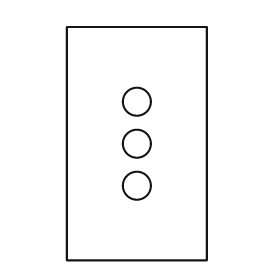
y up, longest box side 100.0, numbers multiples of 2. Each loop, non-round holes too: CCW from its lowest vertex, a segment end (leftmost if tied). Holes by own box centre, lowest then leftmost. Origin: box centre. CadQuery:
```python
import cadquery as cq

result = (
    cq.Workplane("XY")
    .moveTo(-30.0, -50.0)
    .lineTo(30.0, -50.0)
    .lineTo(30.0, 50.0)
    .lineTo(-30.0, 50.0)
    .close()
    .moveTo(0.0, -18.0)
    .circle(6.0)
    .moveTo(0.0, 0.0)
    .circle(6.0)
    .moveTo(0.0, 18.0)
    .circle(6.0)
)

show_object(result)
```